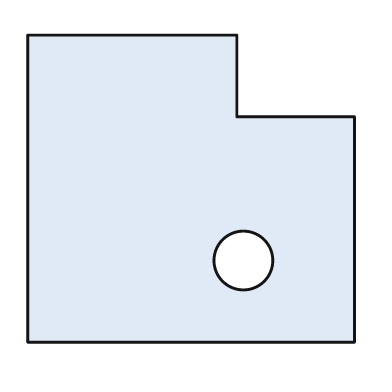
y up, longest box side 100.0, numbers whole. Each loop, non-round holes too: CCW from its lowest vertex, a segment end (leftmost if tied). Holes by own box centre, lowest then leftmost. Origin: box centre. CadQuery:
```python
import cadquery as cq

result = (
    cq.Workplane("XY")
    .moveTo(-50.0, -47.0)
    .lineTo(50.0, -47.0)
    .lineTo(50.0, 22.0)
    .lineTo(14.0, 22.0)
    .lineTo(14.0, 47.0)
    .lineTo(-50.0, 47.0)
    .close()
    .moveTo(16.0, -22.0)
    .circle(9.0)
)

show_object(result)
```